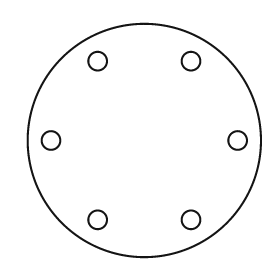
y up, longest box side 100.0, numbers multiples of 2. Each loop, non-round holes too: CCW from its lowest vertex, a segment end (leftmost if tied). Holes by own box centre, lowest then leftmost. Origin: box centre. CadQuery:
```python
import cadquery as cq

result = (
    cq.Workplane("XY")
    .moveTo(0.0, 0.0)
    .circle(50.0)
    .moveTo(-20.0, -34.0)
    .circle(4.0)
    .moveTo(20.0, -34.0)
    .circle(4.0)
    .moveTo(-40.0, 0.0)
    .circle(4.0)
    .moveTo(40.0, 0.0)
    .circle(4.0)
    .moveTo(-20.0, 34.0)
    .circle(4.0)
    .moveTo(20.0, 34.0)
    .circle(4.0)
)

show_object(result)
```